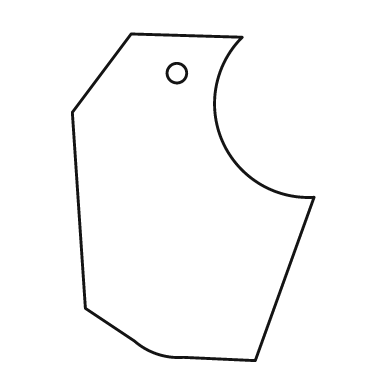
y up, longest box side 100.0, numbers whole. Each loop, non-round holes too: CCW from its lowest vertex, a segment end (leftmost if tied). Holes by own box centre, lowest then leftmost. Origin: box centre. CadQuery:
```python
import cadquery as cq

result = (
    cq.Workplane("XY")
    .moveTo(19.0, -50.0)
    .lineTo(37.0, 0.0)
    .threePointArc((9.0, 17.0), (15.0, 49.0))
    .lineTo(-19.0, 50.0)
    .lineTo(-37.0, 26.0)
    .lineTo(-33.0, -34.0)
    .lineTo(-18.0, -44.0)
    .threePointArc((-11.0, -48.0), (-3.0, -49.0))
    .close()
    .moveTo(-5.0, 38.0)
    .circle(3.0)
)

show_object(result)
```